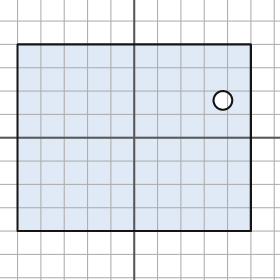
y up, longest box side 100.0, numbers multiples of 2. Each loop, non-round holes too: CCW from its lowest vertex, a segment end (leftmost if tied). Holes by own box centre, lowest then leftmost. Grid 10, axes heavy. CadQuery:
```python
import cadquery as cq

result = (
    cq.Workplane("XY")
    .moveTo(-50.0, -40.0)
    .lineTo(50.0, -40.0)
    .lineTo(50.0, 40.0)
    .lineTo(-50.0, 40.0)
    .close()
    .moveTo(38.0, 16.0)
    .circle(4.0)
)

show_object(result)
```